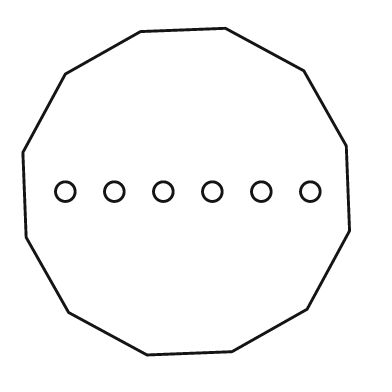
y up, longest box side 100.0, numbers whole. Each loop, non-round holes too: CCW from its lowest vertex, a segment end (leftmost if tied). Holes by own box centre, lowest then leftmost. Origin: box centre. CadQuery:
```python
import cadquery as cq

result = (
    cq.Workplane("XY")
    .moveTo(-12.0, -50.0)
    .lineTo(14.0, -49.0)
    .lineTo(37.0, -36.0)
    .lineTo(50.0, -12.0)
    .lineTo(49.0, 14.0)
    .lineTo(36.0, 37.0)
    .lineTo(12.0, 50.0)
    .lineTo(-14.0, 49.0)
    .lineTo(-37.0, 36.0)
    .lineTo(-50.0, 12.0)
    .lineTo(-49.0, -14.0)
    .lineTo(-36.0, -37.0)
    .close()
    .moveTo(-37.0, 0.0)
    .circle(3.0)
    .moveTo(-22.0, 0.0)
    .circle(3.0)
    .moveTo(-7.0, 0.0)
    .circle(3.0)
    .moveTo(8.0, 0.0)
    .circle(3.0)
    .moveTo(23.0, 0.0)
    .circle(3.0)
    .moveTo(38.0, 0.0)
    .circle(3.0)
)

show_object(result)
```